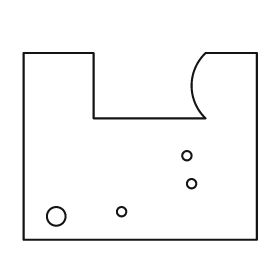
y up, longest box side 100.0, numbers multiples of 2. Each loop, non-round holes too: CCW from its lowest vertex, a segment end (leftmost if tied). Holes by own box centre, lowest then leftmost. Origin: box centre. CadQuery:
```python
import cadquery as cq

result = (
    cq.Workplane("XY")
    .moveTo(-50.0, -40.0)
    .lineTo(50.0, -40.0)
    .lineTo(50.0, 40.0)
    .lineTo(28.0, 40.0)
    .threePointArc((22.0, 26.0), (28.0, 12.0))
    .lineTo(-20.0, 12.0)
    .lineTo(-20.0, 40.0)
    .lineTo(-50.0, 40.0)
    .close()
    .moveTo(-36.0, -30.0)
    .circle(4.0)
    .moveTo(-8.0, -28.0)
    .circle(2.0)
    .moveTo(22.0, -16.0)
    .circle(2.0)
    .moveTo(20.0, -4.0)
    .circle(2.0)
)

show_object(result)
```